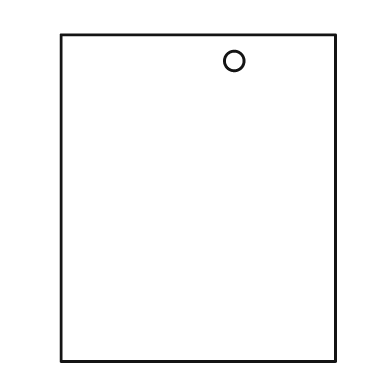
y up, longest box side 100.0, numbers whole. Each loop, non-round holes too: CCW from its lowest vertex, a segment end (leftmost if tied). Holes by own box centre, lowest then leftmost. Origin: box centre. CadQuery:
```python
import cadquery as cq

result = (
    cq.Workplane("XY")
    .moveTo(-42.0, -50.0)
    .lineTo(42.0, -50.0)
    .lineTo(42.0, 50.0)
    .lineTo(-42.0, 50.0)
    .close()
    .moveTo(11.0, 42.0)
    .circle(3.0)
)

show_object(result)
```